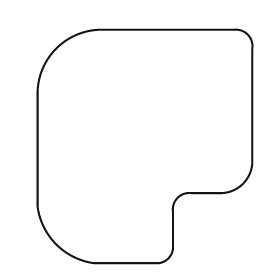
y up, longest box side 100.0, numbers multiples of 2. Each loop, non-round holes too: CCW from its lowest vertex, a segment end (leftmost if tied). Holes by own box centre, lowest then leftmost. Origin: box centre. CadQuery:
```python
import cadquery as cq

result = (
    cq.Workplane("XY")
    .moveTo(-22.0, -50.0)
    .lineTo(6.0, -50.0)
    .threePointArc((10.0, -48.0), (12.0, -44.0))
    .lineTo(12.0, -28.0)
    .threePointArc((14.0, -22.0), (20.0, -20.0))
    .lineTo(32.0, -20.0)
    .threePointArc((42.0, -16.0), (46.0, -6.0))
    .lineTo(46.0, 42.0)
    .threePointArc((44.0, 48.0), (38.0, 50.0))
    .lineTo(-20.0, 50.0)
    .threePointArc((-38.0, 42.0), (-46.0, 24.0))
    .lineTo(-46.0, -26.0)
    .threePointArc((-38.0, -42.0), (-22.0, -50.0))
    .close()
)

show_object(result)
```